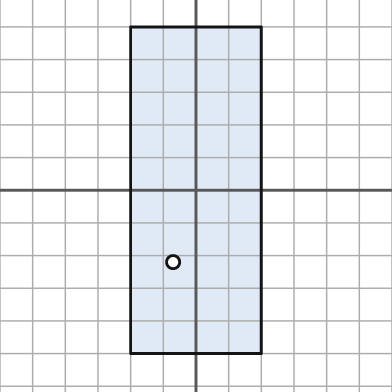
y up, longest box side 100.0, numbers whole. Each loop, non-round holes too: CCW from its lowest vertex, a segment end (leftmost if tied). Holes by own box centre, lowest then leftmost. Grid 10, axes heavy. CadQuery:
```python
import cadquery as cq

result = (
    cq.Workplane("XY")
    .moveTo(-20.0, -50.0)
    .lineTo(20.0, -50.0)
    .lineTo(20.0, 50.0)
    .lineTo(-20.0, 50.0)
    .close()
    .moveTo(-7.0, -22.0)
    .circle(2.0)
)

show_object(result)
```